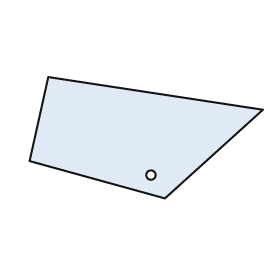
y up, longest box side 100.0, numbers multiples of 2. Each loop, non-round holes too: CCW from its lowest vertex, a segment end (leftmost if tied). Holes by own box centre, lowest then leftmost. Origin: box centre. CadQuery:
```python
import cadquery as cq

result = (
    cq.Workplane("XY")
    .moveTo(8.0, -26.0)
    .lineTo(50.0, 12.0)
    .lineTo(-42.0, 26.0)
    .lineTo(-50.0, -10.0)
    .close()
    .moveTo(2.0, -16.0)
    .circle(2.0)
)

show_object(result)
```